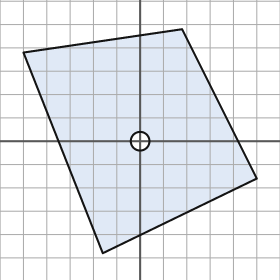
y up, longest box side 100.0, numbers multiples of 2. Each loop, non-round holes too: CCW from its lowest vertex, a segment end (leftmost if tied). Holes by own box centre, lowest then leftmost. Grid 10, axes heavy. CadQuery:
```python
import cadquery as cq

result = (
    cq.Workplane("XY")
    .moveTo(-16.0, -48.0)
    .lineTo(50.0, -16.0)
    .lineTo(18.0, 48.0)
    .lineTo(-50.0, 38.0)
    .close()
    .moveTo(0.0, 0.0)
    .circle(4.0)
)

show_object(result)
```